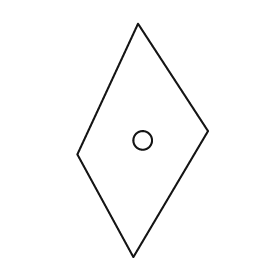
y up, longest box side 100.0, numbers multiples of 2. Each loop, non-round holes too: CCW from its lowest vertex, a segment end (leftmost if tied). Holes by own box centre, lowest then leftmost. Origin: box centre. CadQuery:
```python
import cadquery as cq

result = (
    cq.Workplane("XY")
    .moveTo(-4.0, -50.0)
    .lineTo(28.0, 4.0)
    .lineTo(-2.0, 50.0)
    .lineTo(-28.0, -6.0)
    .close()
    .moveTo(0.0, 0.0)
    .circle(4.0)
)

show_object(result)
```